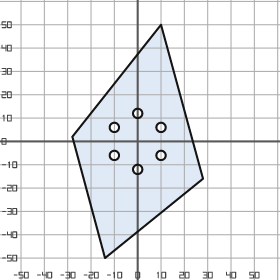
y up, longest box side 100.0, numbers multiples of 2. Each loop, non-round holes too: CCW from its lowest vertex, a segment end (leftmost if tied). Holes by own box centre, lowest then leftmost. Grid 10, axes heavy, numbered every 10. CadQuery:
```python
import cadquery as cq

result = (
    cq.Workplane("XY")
    .moveTo(-14.0, -50.0)
    .lineTo(28.0, -16.0)
    .lineTo(10.0, 50.0)
    .lineTo(-28.0, 2.0)
    .close()
    .moveTo(0.0, -12.0)
    .circle(2.0)
    .moveTo(-10.0, -6.0)
    .circle(2.0)
    .moveTo(10.0, -6.0)
    .circle(2.0)
    .moveTo(-10.0, 6.0)
    .circle(2.0)
    .moveTo(10.0, 6.0)
    .circle(2.0)
    .moveTo(0.0, 12.0)
    .circle(2.0)
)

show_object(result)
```